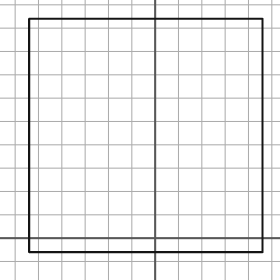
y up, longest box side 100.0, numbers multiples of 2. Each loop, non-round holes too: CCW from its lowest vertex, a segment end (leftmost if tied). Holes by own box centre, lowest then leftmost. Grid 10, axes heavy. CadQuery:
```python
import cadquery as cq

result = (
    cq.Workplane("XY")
    .moveTo(-54.0, -6.0)
    .lineTo(46.0, -6.0)
    .lineTo(46.0, 94.0)
    .lineTo(-54.0, 94.0)
    .close()
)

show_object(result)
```